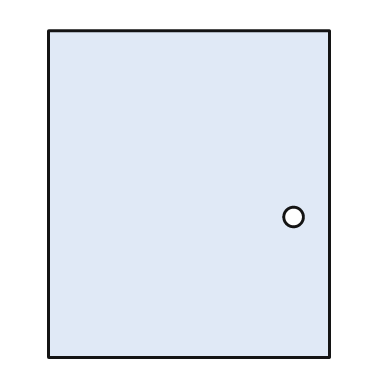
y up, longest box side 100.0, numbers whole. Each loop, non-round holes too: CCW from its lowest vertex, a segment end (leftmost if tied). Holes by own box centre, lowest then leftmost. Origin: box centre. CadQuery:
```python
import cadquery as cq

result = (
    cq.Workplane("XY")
    .moveTo(-43.0, -50.0)
    .lineTo(43.0, -50.0)
    .lineTo(43.0, 50.0)
    .lineTo(-43.0, 50.0)
    .close()
    .moveTo(32.0, -7.0)
    .circle(3.0)
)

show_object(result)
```